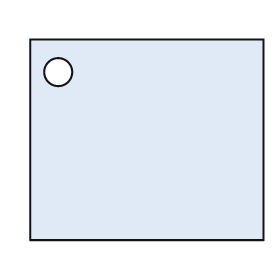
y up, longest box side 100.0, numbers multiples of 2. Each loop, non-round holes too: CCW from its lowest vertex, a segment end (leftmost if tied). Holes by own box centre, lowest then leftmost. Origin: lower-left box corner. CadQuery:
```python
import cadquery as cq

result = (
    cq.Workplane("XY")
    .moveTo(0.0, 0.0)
    .lineTo(100.0, 0.0)
    .lineTo(100.0, 86.0)
    .lineTo(0.0, 86.0)
    .close()
    .moveTo(12.0, 72.0)
    .circle(6.0)
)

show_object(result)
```